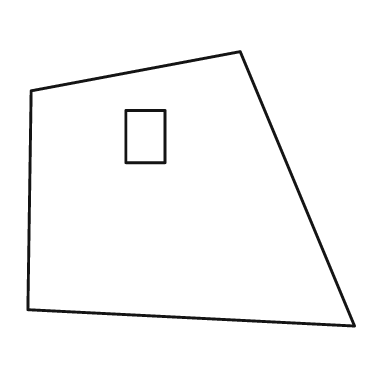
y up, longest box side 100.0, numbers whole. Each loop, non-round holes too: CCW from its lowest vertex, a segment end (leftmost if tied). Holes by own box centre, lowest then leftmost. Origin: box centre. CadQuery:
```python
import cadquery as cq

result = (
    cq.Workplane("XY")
    .moveTo(50.0, -42.0)
    .lineTo(15.0, 42.0)
    .lineTo(-49.0, 30.0)
    .lineTo(-50.0, -37.0)
    .close()
    .moveTo(-20.0, 8.0)
    .lineTo(-8.0, 8.0)
    .lineTo(-8.0, 24.0)
    .lineTo(-20.0, 24.0)
    .close()
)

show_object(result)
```